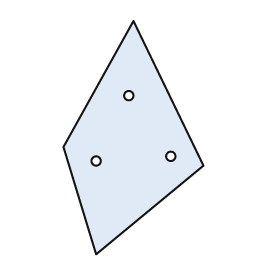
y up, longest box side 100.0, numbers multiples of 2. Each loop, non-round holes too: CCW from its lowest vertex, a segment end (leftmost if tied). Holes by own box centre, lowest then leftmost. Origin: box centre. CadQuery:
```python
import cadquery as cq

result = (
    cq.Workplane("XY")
    .moveTo(-16.0, -50.0)
    .lineTo(30.0, -12.0)
    .lineTo(0.0, 50.0)
    .lineTo(-30.0, -4.0)
    .close()
    .moveTo(-16.0, -10.0)
    .circle(2.0)
    .moveTo(16.0, -8.0)
    .circle(2.0)
    .moveTo(-2.0, 18.0)
    .circle(2.0)
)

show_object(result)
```